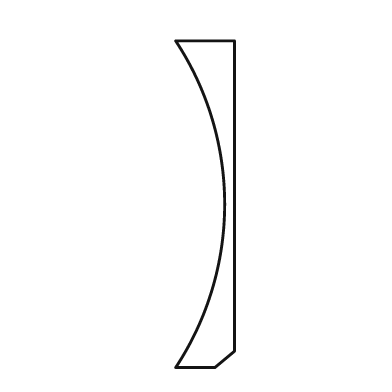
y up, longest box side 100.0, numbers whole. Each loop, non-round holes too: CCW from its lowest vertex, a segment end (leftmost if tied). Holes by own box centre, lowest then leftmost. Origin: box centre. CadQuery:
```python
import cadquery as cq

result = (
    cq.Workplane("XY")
    .moveTo(-9.0, -50.0)
    .lineTo(3.0, -50.0)
    .lineTo(9.0, -45.0)
    .lineTo(9.0, 50.0)
    .lineTo(-9.0, 50.0)
    .threePointArc((6.0, 0.0), (-9.0, -50.0))
    .close()
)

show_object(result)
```